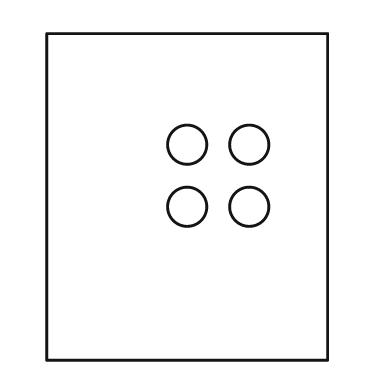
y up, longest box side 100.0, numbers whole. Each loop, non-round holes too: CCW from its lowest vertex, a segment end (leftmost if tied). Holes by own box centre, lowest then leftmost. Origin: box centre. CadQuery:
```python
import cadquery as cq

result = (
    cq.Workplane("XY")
    .moveTo(-43.0, -50.0)
    .lineTo(43.0, -50.0)
    .lineTo(43.0, 50.0)
    .lineTo(-43.0, 50.0)
    .close()
    .moveTo(0.0, -3.0)
    .circle(6.0)
    .moveTo(19.0, -3.0)
    .circle(6.0)
    .moveTo(0.0, 16.0)
    .circle(6.0)
    .moveTo(19.0, 16.0)
    .circle(6.0)
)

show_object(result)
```